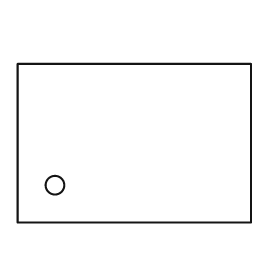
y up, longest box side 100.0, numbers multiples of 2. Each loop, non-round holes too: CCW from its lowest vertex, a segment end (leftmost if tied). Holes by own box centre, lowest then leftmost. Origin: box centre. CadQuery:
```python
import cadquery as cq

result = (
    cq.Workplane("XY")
    .moveTo(-50.0, -34.0)
    .lineTo(50.0, -34.0)
    .lineTo(50.0, 34.0)
    .lineTo(-50.0, 34.0)
    .close()
    .moveTo(-34.0, -18.0)
    .circle(4.0)
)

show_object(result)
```